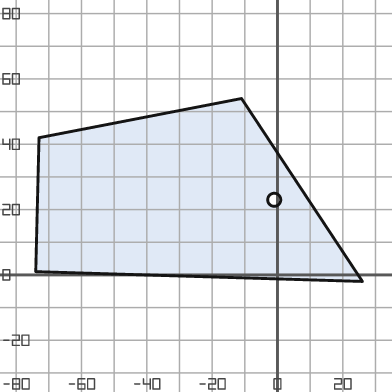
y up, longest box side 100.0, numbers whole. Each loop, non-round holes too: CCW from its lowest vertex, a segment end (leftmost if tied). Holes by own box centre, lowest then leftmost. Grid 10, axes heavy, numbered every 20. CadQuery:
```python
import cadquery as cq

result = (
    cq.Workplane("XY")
    .moveTo(26.0, -2.0)
    .lineTo(-11.0, 54.0)
    .lineTo(-73.0, 42.0)
    .lineTo(-74.0, 1.0)
    .close()
    .moveTo(-1.0, 23.0)
    .circle(2.0)
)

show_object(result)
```